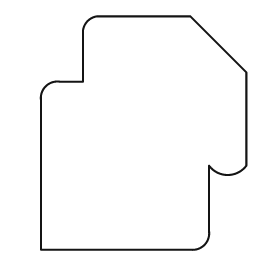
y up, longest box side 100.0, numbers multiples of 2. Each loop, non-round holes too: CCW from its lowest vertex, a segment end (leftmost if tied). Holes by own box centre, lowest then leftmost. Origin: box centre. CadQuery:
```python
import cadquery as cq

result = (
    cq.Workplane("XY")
    .moveTo(-44.0, -50.0)
    .lineTo(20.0, -50.0)
    .threePointArc((26.0, -48.0), (28.0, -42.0))
    .lineTo(28.0, -14.0)
    .threePointArc((36.0, -18.0), (44.0, -14.0))
    .lineTo(44.0, 26.0)
    .lineTo(20.0, 50.0)
    .lineTo(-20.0, 50.0)
    .threePointArc((-24.0, 48.0), (-26.0, 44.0))
    .lineTo(-26.0, 22.0)
    .lineTo(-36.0, 22.0)
    .threePointArc((-42.0, 20.0), (-44.0, 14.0))
    .close()
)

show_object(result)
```